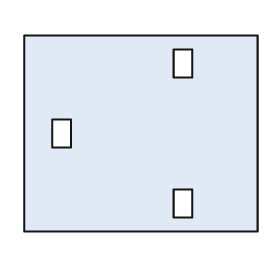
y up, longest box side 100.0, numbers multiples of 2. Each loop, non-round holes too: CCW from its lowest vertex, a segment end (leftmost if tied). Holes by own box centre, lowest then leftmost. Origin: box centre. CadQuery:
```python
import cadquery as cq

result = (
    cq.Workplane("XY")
    .moveTo(-50.0, -42.0)
    .lineTo(50.0, -42.0)
    .lineTo(50.0, 42.0)
    .lineTo(-50.0, 42.0)
    .close()
    .moveTo(14.0, -36.0)
    .lineTo(22.0, -36.0)
    .lineTo(22.0, -24.0)
    .lineTo(14.0, -24.0)
    .close()
    .moveTo(-38.0, -6.0)
    .lineTo(-30.0, -6.0)
    .lineTo(-30.0, 6.0)
    .lineTo(-38.0, 6.0)
    .close()
    .moveTo(14.0, 24.0)
    .lineTo(22.0, 24.0)
    .lineTo(22.0, 36.0)
    .lineTo(14.0, 36.0)
    .close()
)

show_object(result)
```